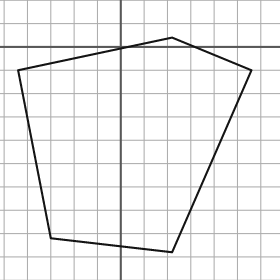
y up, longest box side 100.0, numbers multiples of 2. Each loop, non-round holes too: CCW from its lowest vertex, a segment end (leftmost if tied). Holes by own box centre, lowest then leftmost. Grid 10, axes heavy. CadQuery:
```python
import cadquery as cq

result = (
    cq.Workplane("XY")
    .moveTo(22.0, -88.0)
    .lineTo(56.0, -10.0)
    .lineTo(22.0, 4.0)
    .lineTo(-44.0, -10.0)
    .lineTo(-30.0, -82.0)
    .close()
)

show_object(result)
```